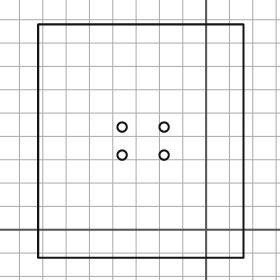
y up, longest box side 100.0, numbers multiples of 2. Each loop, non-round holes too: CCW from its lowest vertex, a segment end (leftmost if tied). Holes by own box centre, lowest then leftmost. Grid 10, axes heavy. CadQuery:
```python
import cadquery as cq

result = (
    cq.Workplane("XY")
    .moveTo(-72.0, -12.0)
    .lineTo(16.0, -12.0)
    .lineTo(16.0, 88.0)
    .lineTo(-72.0, 88.0)
    .close()
    .moveTo(-36.0, 32.0)
    .circle(2.0)
    .moveTo(-18.0, 32.0)
    .circle(2.0)
    .moveTo(-36.0, 44.0)
    .circle(2.0)
    .moveTo(-18.0, 44.0)
    .circle(2.0)
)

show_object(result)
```